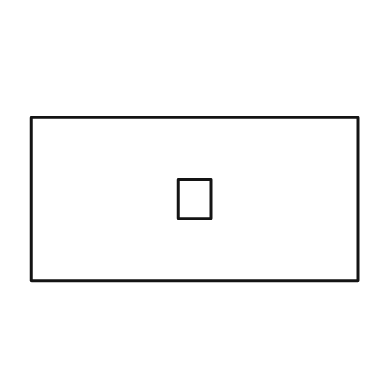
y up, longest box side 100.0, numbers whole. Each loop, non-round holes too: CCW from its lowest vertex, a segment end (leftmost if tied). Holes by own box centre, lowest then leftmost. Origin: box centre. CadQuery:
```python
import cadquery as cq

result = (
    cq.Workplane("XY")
    .moveTo(-50.0, -25.0)
    .lineTo(50.0, -25.0)
    .lineTo(50.0, 25.0)
    .lineTo(-50.0, 25.0)
    .close()
    .moveTo(-5.0, -6.0)
    .lineTo(5.0, -6.0)
    .lineTo(5.0, 6.0)
    .lineTo(-5.0, 6.0)
    .close()
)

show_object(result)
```